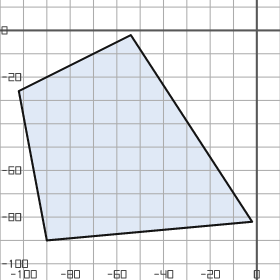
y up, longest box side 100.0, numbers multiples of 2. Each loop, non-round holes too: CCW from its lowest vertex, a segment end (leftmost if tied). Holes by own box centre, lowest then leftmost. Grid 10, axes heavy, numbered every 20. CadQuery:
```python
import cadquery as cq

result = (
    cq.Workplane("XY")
    .moveTo(-90.0, -90.0)
    .lineTo(-2.0, -82.0)
    .lineTo(-54.0, -2.0)
    .lineTo(-102.0, -26.0)
    .close()
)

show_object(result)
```